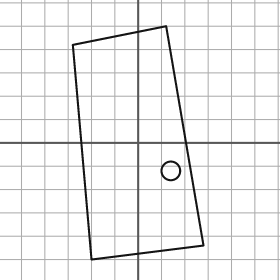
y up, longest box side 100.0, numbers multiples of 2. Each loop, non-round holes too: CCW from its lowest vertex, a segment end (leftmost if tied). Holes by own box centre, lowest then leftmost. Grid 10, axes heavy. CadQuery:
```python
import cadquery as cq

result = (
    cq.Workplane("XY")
    .moveTo(-20.0, -50.0)
    .lineTo(28.0, -44.0)
    .lineTo(12.0, 50.0)
    .lineTo(-28.0, 42.0)
    .close()
    .moveTo(14.0, -12.0)
    .circle(4.0)
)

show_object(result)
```